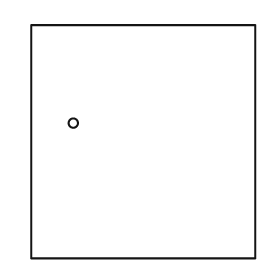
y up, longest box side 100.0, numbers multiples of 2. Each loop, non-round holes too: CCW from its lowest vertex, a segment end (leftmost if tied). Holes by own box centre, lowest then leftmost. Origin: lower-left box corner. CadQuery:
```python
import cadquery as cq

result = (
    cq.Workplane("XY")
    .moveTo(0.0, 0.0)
    .lineTo(96.0, 0.0)
    .lineTo(96.0, 100.0)
    .lineTo(0.0, 100.0)
    .close()
    .moveTo(18.0, 58.0)
    .circle(2.0)
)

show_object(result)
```